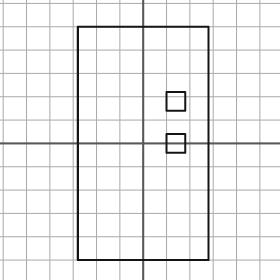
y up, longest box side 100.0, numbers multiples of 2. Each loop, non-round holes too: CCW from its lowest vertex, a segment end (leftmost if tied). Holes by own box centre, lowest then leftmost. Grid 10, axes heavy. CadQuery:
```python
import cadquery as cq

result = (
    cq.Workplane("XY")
    .moveTo(-28.0, -50.0)
    .lineTo(28.0, -50.0)
    .lineTo(28.0, 50.0)
    .lineTo(-28.0, 50.0)
    .close()
    .moveTo(10.0, -4.0)
    .lineTo(18.0, -4.0)
    .lineTo(18.0, 4.0)
    .lineTo(10.0, 4.0)
    .close()
    .moveTo(10.0, 14.0)
    .lineTo(18.0, 14.0)
    .lineTo(18.0, 22.0)
    .lineTo(10.0, 22.0)
    .close()
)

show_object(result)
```